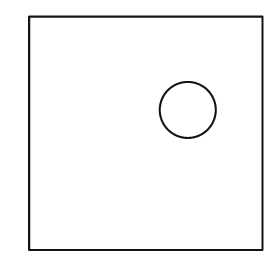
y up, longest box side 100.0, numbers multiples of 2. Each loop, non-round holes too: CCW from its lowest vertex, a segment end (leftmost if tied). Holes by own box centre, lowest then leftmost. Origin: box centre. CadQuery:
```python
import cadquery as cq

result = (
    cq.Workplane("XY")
    .moveTo(-50.0, -50.0)
    .lineTo(50.0, -50.0)
    .lineTo(50.0, 50.0)
    .lineTo(-50.0, 50.0)
    .close()
    .moveTo(18.0, 10.0)
    .circle(12.0)
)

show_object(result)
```